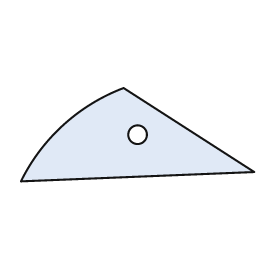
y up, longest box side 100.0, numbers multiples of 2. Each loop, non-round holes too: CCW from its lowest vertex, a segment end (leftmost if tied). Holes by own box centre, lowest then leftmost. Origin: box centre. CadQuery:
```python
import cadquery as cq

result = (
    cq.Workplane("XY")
    .moveTo(-50.0, -20.0)
    .lineTo(50.0, -16.0)
    .lineTo(-6.0, 20.0)
    .threePointArc((-32.0, 4.0), (-50.0, -20.0))
    .close()
    .moveTo(0.0, 0.0)
    .circle(4.0)
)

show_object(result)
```